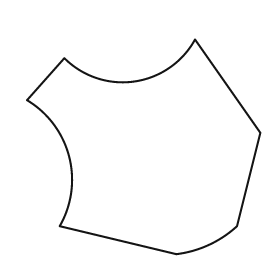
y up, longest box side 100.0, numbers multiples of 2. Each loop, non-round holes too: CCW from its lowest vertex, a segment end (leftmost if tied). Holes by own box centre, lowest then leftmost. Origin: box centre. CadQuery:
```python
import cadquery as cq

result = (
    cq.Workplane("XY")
    .moveTo(14.0, -46.0)
    .threePointArc((28.0, -42.0), (40.0, -34.0))
    .lineTo(50.0, 6.0)
    .lineTo(22.0, 46.0)
    .threePointArc((-4.0, 28.0), (-34.0, 38.0))
    .lineTo(-50.0, 20.0)
    .threePointArc((-32.0, -4.0), (-36.0, -34.0))
    .close()
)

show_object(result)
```